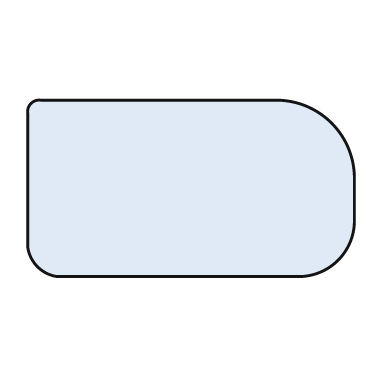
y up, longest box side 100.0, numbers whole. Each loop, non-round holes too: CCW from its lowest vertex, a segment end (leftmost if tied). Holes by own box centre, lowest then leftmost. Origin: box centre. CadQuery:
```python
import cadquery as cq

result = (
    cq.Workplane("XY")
    .moveTo(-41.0, -27.0)
    .lineTo(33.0, -27.0)
    .threePointArc((45.0, -22.0), (50.0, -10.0))
    .lineTo(50.0, 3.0)
    .threePointArc((43.0, 20.0), (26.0, 27.0))
    .lineTo(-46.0, 27.0)
    .threePointArc((-49.0, 26.0), (-50.0, 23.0))
    .lineTo(-50.0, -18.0)
    .threePointArc((-47.0, -24.0), (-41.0, -27.0))
    .close()
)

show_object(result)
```